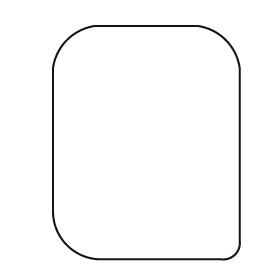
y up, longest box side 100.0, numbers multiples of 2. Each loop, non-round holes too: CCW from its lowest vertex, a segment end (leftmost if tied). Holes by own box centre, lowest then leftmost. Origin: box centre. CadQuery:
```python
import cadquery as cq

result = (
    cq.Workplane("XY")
    .moveTo(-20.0, -50.0)
    .lineTo(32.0, -50.0)
    .threePointArc((38.0, -48.0), (40.0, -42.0))
    .lineTo(40.0, 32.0)
    .threePointArc((34.0, 44.0), (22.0, 50.0))
    .lineTo(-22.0, 50.0)
    .threePointArc((-34.0, 44.0), (-40.0, 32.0))
    .lineTo(-40.0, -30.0)
    .threePointArc((-34.0, -44.0), (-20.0, -50.0))
    .close()
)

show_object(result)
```